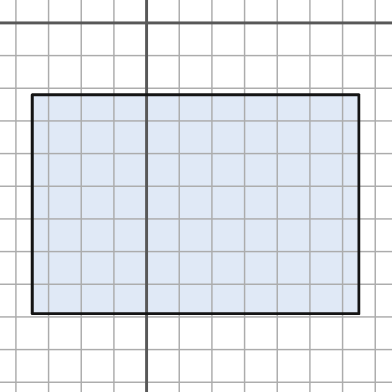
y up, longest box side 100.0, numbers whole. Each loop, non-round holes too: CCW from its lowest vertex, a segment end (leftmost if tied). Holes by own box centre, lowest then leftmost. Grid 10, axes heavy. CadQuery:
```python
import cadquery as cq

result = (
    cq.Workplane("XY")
    .moveTo(-35.0, -89.0)
    .lineTo(65.0, -89.0)
    .lineTo(65.0, -22.0)
    .lineTo(-35.0, -22.0)
    .close()
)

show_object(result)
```